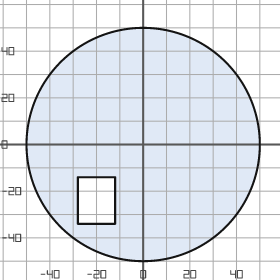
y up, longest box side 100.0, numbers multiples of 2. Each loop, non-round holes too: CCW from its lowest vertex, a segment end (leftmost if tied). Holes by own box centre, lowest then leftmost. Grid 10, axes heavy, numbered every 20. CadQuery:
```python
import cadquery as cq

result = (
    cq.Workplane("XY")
    .moveTo(0.0, 0.0)
    .circle(50.0)
    .moveTo(-28.0, -34.0)
    .lineTo(-12.0, -34.0)
    .lineTo(-12.0, -14.0)
    .lineTo(-28.0, -14.0)
    .close()
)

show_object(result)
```